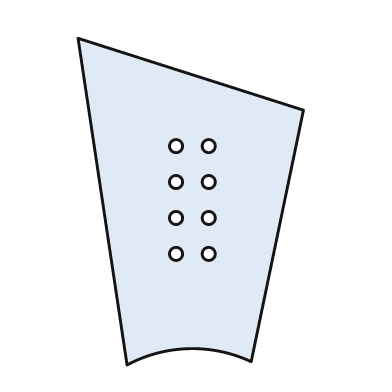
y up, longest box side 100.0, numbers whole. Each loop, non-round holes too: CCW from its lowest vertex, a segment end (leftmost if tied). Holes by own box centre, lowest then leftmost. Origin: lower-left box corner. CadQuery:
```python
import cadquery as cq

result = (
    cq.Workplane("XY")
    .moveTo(15.0, 0.0)
    .threePointArc((34.0, 5.0), (53.0, 1.0))
    .lineTo(69.0, 78.0)
    .lineTo(0.0, 100.0)
    .close()
    .moveTo(30.0, 34.0)
    .circle(2.0)
    .moveTo(40.0, 34.0)
    .circle(2.0)
    .moveTo(30.0, 45.0)
    .circle(2.0)
    .moveTo(40.0, 45.0)
    .circle(2.0)
    .moveTo(30.0, 56.0)
    .circle(2.0)
    .moveTo(40.0, 56.0)
    .circle(2.0)
    .moveTo(30.0, 67.0)
    .circle(2.0)
    .moveTo(40.0, 67.0)
    .circle(2.0)
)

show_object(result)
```